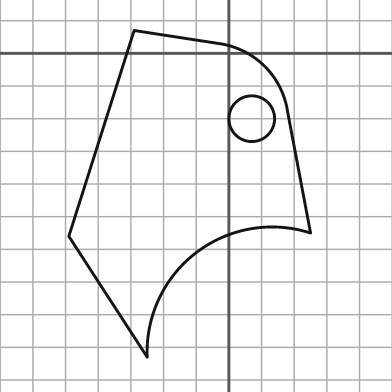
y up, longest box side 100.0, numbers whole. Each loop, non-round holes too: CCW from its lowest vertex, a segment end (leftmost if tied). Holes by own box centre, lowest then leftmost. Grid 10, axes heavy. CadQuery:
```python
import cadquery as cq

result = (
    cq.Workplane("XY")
    .moveTo(-25.0, -93.0)
    .threePointArc((-10.0, -61.0), (25.0, -55.0))
    .lineTo(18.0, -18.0)
    .threePointArc((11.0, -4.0), (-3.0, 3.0))
    .lineTo(-29.0, 7.0)
    .lineTo(-49.0, -56.0)
    .close()
    .moveTo(7.0, -20.0)
    .circle(7.0)
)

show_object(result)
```